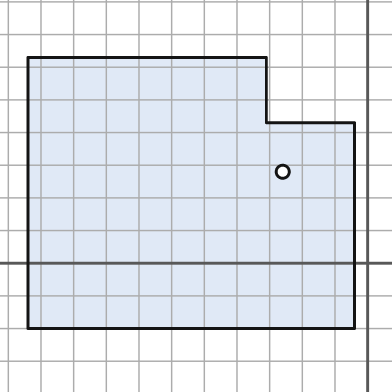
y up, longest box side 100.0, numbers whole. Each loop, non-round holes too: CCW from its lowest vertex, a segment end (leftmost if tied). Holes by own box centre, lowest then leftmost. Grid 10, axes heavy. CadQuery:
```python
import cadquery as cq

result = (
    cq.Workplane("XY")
    .moveTo(-104.0, -20.0)
    .lineTo(-4.0, -20.0)
    .lineTo(-4.0, 43.0)
    .lineTo(-31.0, 43.0)
    .lineTo(-31.0, 63.0)
    .lineTo(-104.0, 63.0)
    .close()
    .moveTo(-26.0, 28.0)
    .circle(2.0)
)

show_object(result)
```